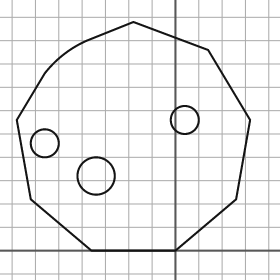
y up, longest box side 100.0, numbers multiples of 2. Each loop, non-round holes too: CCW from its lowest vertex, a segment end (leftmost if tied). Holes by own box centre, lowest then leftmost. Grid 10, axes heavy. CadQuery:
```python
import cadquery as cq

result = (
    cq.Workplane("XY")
    .moveTo(-36.0, 0.0)
    .lineTo(0.0, 0.0)
    .lineTo(26.0, 22.0)
    .lineTo(32.0, 56.0)
    .lineTo(14.0, 86.0)
    .lineTo(-18.0, 98.0)
    .lineTo(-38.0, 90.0)
    .threePointArc((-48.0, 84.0), (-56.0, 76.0))
    .lineTo(-68.0, 56.0)
    .lineTo(-62.0, 22.0)
    .close()
    .moveTo(-34.0, 32.0)
    .circle(8.0)
    .moveTo(-56.0, 46.0)
    .circle(6.0)
    .moveTo(4.0, 56.0)
    .circle(6.0)
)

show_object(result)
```